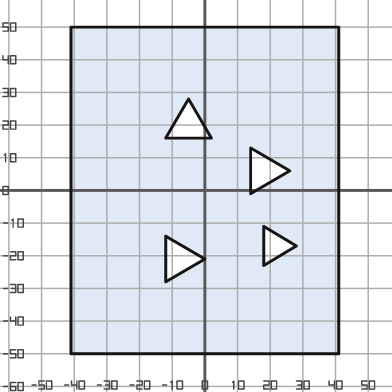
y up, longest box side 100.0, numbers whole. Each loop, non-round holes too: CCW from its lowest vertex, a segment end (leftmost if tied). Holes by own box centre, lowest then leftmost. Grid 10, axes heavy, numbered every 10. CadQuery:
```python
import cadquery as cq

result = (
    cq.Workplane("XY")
    .moveTo(-41.0, -50.0)
    .lineTo(41.0, -50.0)
    .lineTo(41.0, 50.0)
    .lineTo(-41.0, 50.0)
    .close()
    .moveTo(-12.0, -28.0)
    .lineTo(0.0, -21.0)
    .lineTo(-12.0, -14.0)
    .close()
    .moveTo(18.0, -23.0)
    .lineTo(28.0, -17.0)
    .lineTo(18.0, -11.0)
    .close()
    .moveTo(14.0, -1.0)
    .lineTo(26.0, 6.0)
    .lineTo(14.0, 13.0)
    .close()
    .moveTo(-12.0, 16.0)
    .lineTo(2.0, 16.0)
    .lineTo(-5.0, 28.0)
    .close()
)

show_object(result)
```